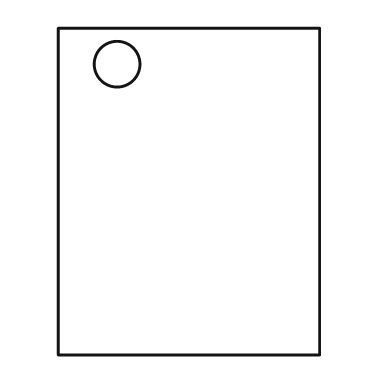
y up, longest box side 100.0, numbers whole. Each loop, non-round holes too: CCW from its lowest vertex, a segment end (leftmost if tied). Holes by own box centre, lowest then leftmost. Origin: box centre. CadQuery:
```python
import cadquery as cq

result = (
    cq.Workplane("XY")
    .moveTo(-40.0, -50.0)
    .lineTo(40.0, -50.0)
    .lineTo(40.0, 50.0)
    .lineTo(-40.0, 50.0)
    .close()
    .moveTo(-22.0, 39.0)
    .circle(7.0)
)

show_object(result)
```